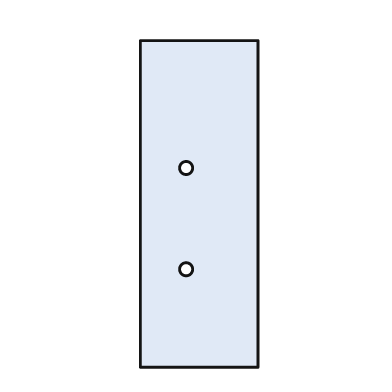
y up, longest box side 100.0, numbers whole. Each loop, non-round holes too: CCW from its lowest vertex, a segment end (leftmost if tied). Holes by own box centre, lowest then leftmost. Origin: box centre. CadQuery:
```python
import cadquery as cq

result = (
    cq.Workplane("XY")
    .moveTo(-18.0, -50.0)
    .lineTo(18.0, -50.0)
    .lineTo(18.0, 50.0)
    .lineTo(-18.0, 50.0)
    .close()
    .moveTo(-4.0, -20.0)
    .circle(2.0)
    .moveTo(-4.0, 11.0)
    .circle(2.0)
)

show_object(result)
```